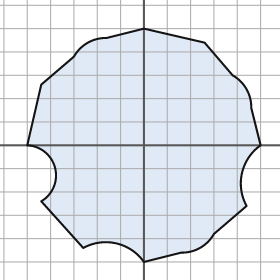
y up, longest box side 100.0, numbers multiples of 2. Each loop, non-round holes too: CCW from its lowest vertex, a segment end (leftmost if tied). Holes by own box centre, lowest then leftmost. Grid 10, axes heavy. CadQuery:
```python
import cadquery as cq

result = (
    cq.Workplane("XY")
    .moveTo(0.0, -50.0)
    .lineTo(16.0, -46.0)
    .threePointArc((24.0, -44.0), (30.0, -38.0))
    .lineTo(44.0, -26.0)
    .threePointArc((42.0, -12.0), (50.0, 0.0))
    .lineTo(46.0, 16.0)
    .threePointArc((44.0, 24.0), (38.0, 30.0))
    .lineTo(26.0, 44.0)
    .lineTo(0.0, 50.0)
    .lineTo(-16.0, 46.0)
    .threePointArc((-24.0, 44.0), (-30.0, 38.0))
    .lineTo(-44.0, 26.0)
    .lineTo(-50.0, 0.0)
    .threePointArc((-38.0, -10.0), (-44.0, -24.0))
    .lineTo(-26.0, -44.0)
    .threePointArc((-12.0, -42.0), (0.0, -50.0))
    .close()
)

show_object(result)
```